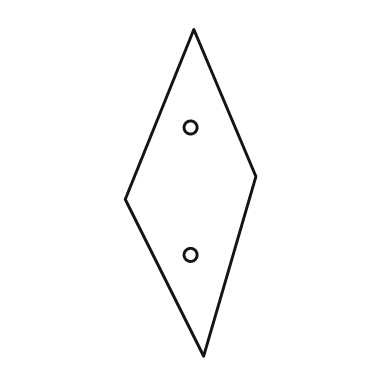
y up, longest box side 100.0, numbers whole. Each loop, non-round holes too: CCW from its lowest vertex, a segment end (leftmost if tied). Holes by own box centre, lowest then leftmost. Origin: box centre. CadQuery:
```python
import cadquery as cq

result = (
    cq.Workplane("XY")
    .moveTo(4.0, -50.0)
    .lineTo(20.0, 5.0)
    .lineTo(1.0, 50.0)
    .lineTo(-20.0, -2.0)
    .close()
    .moveTo(0.0, -19.0)
    .circle(2.0)
    .moveTo(0.0, 20.0)
    .circle(2.0)
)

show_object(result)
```